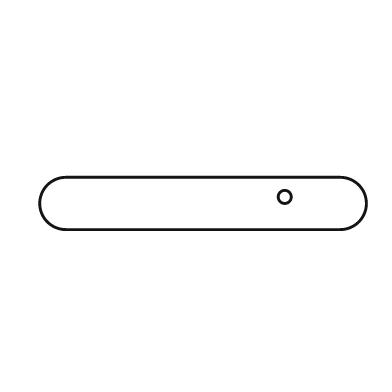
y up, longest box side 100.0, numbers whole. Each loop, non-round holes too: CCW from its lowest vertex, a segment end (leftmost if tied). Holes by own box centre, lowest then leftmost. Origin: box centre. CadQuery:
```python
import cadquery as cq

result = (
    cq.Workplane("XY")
    .moveTo(-42.0, -8.0)
    .lineTo(42.0, -8.0)
    .threePointArc((50.0, 0.0), (42.0, 8.0))
    .lineTo(-42.0, 8.0)
    .threePointArc((-50.0, 0.0), (-42.0, -8.0))
    .close()
    .moveTo(25.0, 2.0)
    .circle(2.0)
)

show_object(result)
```